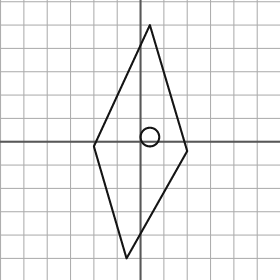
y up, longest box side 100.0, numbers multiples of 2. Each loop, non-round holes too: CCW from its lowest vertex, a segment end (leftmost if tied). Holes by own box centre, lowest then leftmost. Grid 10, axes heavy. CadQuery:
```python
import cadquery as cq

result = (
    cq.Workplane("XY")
    .moveTo(-6.0, -50.0)
    .lineTo(20.0, -4.0)
    .lineTo(4.0, 50.0)
    .lineTo(-20.0, -2.0)
    .close()
    .moveTo(4.0, 2.0)
    .circle(4.0)
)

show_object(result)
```